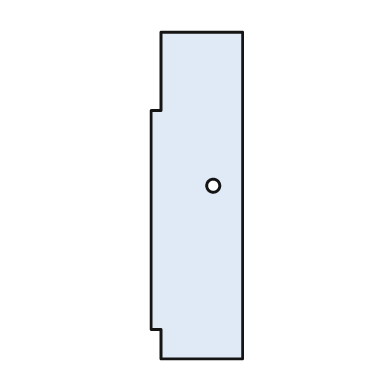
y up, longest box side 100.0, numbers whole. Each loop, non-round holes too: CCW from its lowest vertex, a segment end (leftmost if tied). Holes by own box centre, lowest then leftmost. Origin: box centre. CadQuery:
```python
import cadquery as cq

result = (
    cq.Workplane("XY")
    .moveTo(-11.0, -50.0)
    .lineTo(14.0, -50.0)
    .lineTo(14.0, 50.0)
    .lineTo(-11.0, 50.0)
    .lineTo(-11.0, 26.0)
    .lineTo(-14.0, 26.0)
    .lineTo(-14.0, -41.0)
    .lineTo(-11.0, -41.0)
    .close()
    .moveTo(5.0, 3.0)
    .circle(2.0)
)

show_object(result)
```